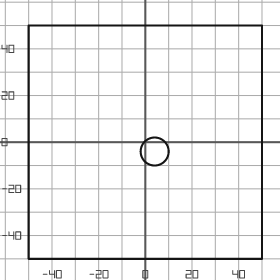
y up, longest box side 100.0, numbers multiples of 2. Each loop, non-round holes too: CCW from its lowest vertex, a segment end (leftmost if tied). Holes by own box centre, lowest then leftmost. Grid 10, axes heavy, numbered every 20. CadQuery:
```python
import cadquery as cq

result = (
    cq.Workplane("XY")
    .moveTo(-50.0, -50.0)
    .lineTo(50.0, -50.0)
    .lineTo(50.0, 50.0)
    .lineTo(-50.0, 50.0)
    .close()
    .moveTo(4.0, -4.0)
    .circle(6.0)
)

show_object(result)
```